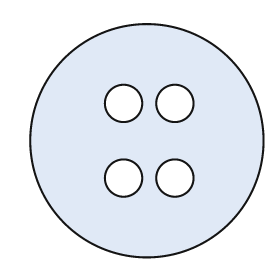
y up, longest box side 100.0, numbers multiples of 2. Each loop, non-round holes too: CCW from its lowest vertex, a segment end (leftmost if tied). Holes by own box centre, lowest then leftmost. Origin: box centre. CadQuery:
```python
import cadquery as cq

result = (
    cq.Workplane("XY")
    .moveTo(0.0, 0.0)
    .circle(50.0)
    .moveTo(-10.0, -16.0)
    .circle(8.0)
    .moveTo(12.0, -16.0)
    .circle(8.0)
    .moveTo(-10.0, 16.0)
    .circle(8.0)
    .moveTo(12.0, 16.0)
    .circle(8.0)
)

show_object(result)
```